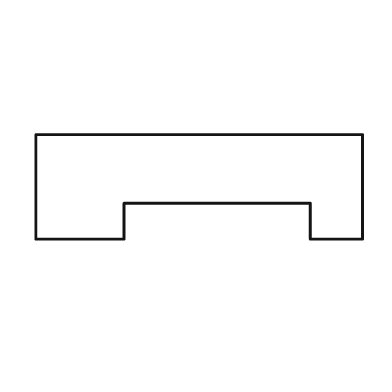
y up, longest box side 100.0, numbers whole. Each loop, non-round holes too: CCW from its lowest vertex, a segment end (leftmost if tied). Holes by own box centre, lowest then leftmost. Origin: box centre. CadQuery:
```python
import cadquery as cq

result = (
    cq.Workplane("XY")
    .moveTo(-50.0, -16.0)
    .lineTo(-23.0, -16.0)
    .lineTo(-23.0, -5.0)
    .lineTo(34.0, -5.0)
    .lineTo(34.0, -16.0)
    .lineTo(50.0, -16.0)
    .lineTo(50.0, 16.0)
    .lineTo(-50.0, 16.0)
    .close()
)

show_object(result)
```